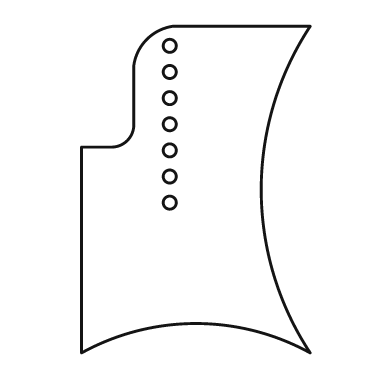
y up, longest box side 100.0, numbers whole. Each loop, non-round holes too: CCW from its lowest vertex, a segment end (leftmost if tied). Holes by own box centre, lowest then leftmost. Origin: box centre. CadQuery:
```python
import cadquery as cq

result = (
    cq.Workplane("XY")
    .moveTo(-35.0, -50.0)
    .threePointArc((0.0, -41.0), (35.0, -50.0))
    .threePointArc((20.0, 0.0), (35.0, 50.0))
    .lineTo(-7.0, 50.0)
    .threePointArc((-15.0, 46.0), (-19.0, 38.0))
    .lineTo(-19.0, 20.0)
    .threePointArc((-21.0, 15.0), (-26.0, 13.0))
    .lineTo(-35.0, 13.0)
    .close()
    .moveTo(-8.0, -4.0)
    .circle(2.0)
    .moveTo(-8.0, 4.0)
    .circle(2.0)
    .moveTo(-8.0, 12.0)
    .circle(2.0)
    .moveTo(-8.0, 20.0)
    .circle(2.0)
    .moveTo(-8.0, 28.0)
    .circle(2.0)
    .moveTo(-8.0, 36.0)
    .circle(2.0)
    .moveTo(-8.0, 44.0)
    .circle(2.0)
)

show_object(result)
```